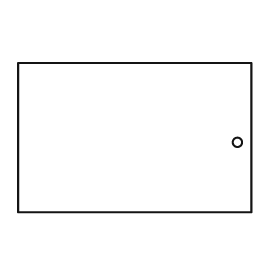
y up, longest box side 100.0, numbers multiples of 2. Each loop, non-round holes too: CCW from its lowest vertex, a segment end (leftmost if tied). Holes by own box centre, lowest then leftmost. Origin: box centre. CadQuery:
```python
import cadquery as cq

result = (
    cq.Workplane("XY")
    .moveTo(-50.0, -32.0)
    .lineTo(50.0, -32.0)
    .lineTo(50.0, 32.0)
    .lineTo(-50.0, 32.0)
    .close()
    .moveTo(44.0, -2.0)
    .circle(2.0)
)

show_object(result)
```